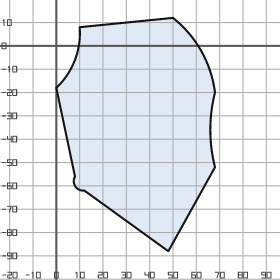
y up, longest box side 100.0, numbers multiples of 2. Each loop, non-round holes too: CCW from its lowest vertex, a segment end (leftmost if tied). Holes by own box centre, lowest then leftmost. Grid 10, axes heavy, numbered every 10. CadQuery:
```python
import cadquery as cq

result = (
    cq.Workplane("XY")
    .moveTo(48.0, -88.0)
    .lineTo(68.0, -52.0)
    .threePointArc((66.0, -36.0), (68.0, -20.0))
    .threePointArc((62.0, -2.0), (50.0, 12.0))
    .lineTo(10.0, 8.0)
    .threePointArc((8.0, -6.0), (0.0, -18.0))
    .lineTo(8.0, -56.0)
    .threePointArc((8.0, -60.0), (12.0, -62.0))
    .close()
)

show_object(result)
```